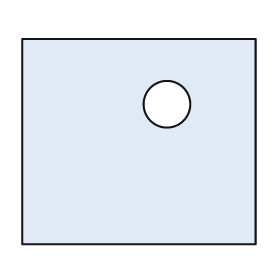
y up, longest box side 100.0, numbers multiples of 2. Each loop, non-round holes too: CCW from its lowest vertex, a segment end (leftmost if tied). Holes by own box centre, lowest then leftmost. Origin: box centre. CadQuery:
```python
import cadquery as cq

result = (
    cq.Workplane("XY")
    .moveTo(-50.0, -44.0)
    .lineTo(50.0, -44.0)
    .lineTo(50.0, 44.0)
    .lineTo(-50.0, 44.0)
    .close()
    .moveTo(12.0, 16.0)
    .circle(10.0)
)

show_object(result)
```